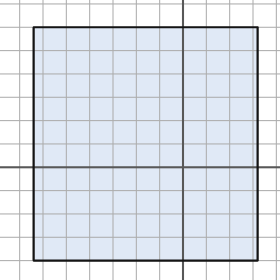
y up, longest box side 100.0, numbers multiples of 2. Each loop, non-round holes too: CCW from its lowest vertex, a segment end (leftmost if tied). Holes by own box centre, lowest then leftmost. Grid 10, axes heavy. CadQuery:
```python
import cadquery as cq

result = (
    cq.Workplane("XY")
    .moveTo(-64.0, -40.0)
    .lineTo(32.0, -40.0)
    .lineTo(32.0, 60.0)
    .lineTo(-64.0, 60.0)
    .close()
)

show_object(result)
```